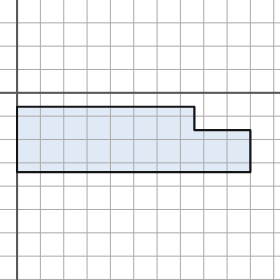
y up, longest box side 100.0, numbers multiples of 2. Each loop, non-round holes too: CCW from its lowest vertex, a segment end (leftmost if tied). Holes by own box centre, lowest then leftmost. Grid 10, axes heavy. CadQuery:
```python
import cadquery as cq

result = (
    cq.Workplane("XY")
    .moveTo(0.0, -34.0)
    .lineTo(100.0, -34.0)
    .lineTo(100.0, -16.0)
    .lineTo(76.0, -16.0)
    .lineTo(76.0, -6.0)
    .lineTo(0.0, -6.0)
    .close()
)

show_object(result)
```